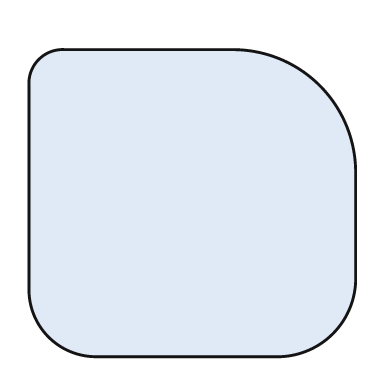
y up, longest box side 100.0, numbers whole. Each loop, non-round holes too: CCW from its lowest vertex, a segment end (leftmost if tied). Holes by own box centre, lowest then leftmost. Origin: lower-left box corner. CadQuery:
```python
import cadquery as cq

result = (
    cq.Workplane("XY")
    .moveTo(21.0, 0.0)
    .lineTo(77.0, 0.0)
    .threePointArc((93.0, 7.0), (100.0, 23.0))
    .lineTo(100.0, 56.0)
    .threePointArc((89.0, 83.0), (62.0, 94.0))
    .lineTo(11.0, 94.0)
    .threePointArc((3.0, 91.0), (0.0, 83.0))
    .lineTo(0.0, 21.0)
    .threePointArc((6.0, 6.0), (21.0, 0.0))
    .close()
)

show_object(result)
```